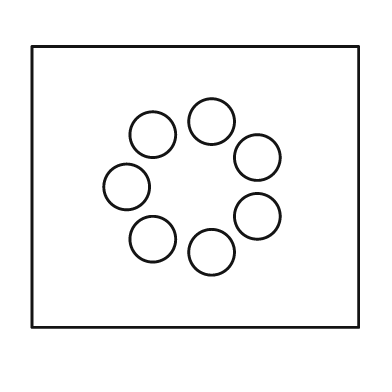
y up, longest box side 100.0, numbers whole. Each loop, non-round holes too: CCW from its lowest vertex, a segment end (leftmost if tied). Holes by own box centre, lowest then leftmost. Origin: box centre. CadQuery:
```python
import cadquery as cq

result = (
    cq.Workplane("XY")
    .moveTo(-50.0, -43.0)
    .lineTo(50.0, -43.0)
    .lineTo(50.0, 43.0)
    .lineTo(-50.0, 43.0)
    .close()
    .moveTo(5.0, -20.0)
    .circle(7.0)
    .moveTo(-13.0, -16.0)
    .circle(7.0)
    .moveTo(19.0, -9.0)
    .circle(7.0)
    .moveTo(-21.0, 0.0)
    .circle(7.0)
    .moveTo(19.0, 9.0)
    .circle(7.0)
    .moveTo(-13.0, 16.0)
    .circle(7.0)
    .moveTo(5.0, 20.0)
    .circle(7.0)
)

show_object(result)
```